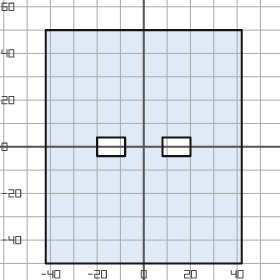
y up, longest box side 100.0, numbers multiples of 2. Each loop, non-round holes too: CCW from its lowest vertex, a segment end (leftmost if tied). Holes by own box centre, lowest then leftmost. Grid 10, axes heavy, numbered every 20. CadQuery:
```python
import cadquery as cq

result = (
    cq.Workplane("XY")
    .moveTo(-42.0, -50.0)
    .lineTo(42.0, -50.0)
    .lineTo(42.0, 50.0)
    .lineTo(-42.0, 50.0)
    .close()
    .moveTo(-20.0, -4.0)
    .lineTo(-8.0, -4.0)
    .lineTo(-8.0, 4.0)
    .lineTo(-20.0, 4.0)
    .close()
    .moveTo(8.0, -4.0)
    .lineTo(20.0, -4.0)
    .lineTo(20.0, 4.0)
    .lineTo(8.0, 4.0)
    .close()
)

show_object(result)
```